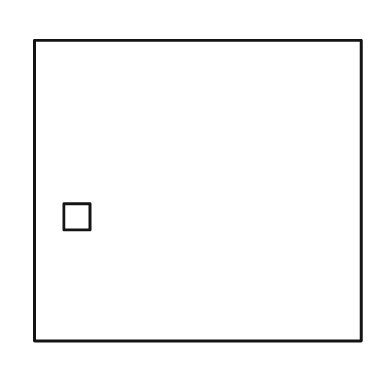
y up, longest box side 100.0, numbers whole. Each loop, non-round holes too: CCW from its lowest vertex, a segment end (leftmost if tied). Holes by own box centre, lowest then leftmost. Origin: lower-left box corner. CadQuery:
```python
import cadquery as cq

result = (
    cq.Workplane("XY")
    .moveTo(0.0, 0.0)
    .lineTo(100.0, 0.0)
    .lineTo(100.0, 92.0)
    .lineTo(0.0, 92.0)
    .close()
    .moveTo(9.0, 34.0)
    .lineTo(17.0, 34.0)
    .lineTo(17.0, 42.0)
    .lineTo(9.0, 42.0)
    .close()
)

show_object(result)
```